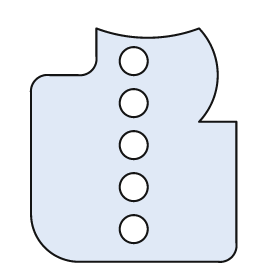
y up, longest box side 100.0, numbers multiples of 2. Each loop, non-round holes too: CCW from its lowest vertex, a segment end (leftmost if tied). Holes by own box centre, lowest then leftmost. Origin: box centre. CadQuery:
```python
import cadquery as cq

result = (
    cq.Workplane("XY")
    .moveTo(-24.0, -50.0)
    .lineTo(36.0, -50.0)
    .threePointArc((42.0, -48.0), (44.0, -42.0))
    .lineTo(44.0, 10.0)
    .lineTo(28.0, 10.0)
    .threePointArc((36.0, 30.0), (28.0, 50.0))
    .threePointArc((6.0, 46.0), (-16.0, 50.0))
    .lineTo(-16.0, 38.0)
    .threePointArc((-18.0, 32.0), (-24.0, 30.0))
    .lineTo(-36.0, 30.0)
    .threePointArc((-42.0, 28.0), (-44.0, 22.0))
    .lineTo(-44.0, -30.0)
    .threePointArc((-38.0, -44.0), (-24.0, -50.0))
    .close()
    .moveTo(0.0, -36.0)
    .circle(6.0)
    .moveTo(0.0, -18.0)
    .circle(6.0)
    .moveTo(0.0, 0.0)
    .circle(6.0)
    .moveTo(0.0, 18.0)
    .circle(6.0)
    .moveTo(0.0, 36.0)
    .circle(6.0)
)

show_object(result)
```